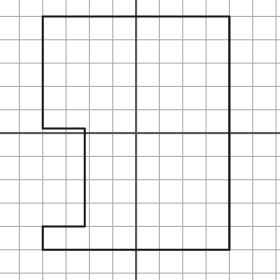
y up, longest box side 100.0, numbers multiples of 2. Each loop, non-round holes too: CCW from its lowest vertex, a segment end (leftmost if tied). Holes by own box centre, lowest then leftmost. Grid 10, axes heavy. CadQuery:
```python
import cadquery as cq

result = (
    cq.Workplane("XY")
    .moveTo(-40.0, -50.0)
    .lineTo(40.0, -50.0)
    .lineTo(40.0, 50.0)
    .lineTo(-40.0, 50.0)
    .lineTo(-40.0, 2.0)
    .lineTo(-22.0, 2.0)
    .lineTo(-22.0, -40.0)
    .lineTo(-40.0, -40.0)
    .close()
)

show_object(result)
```